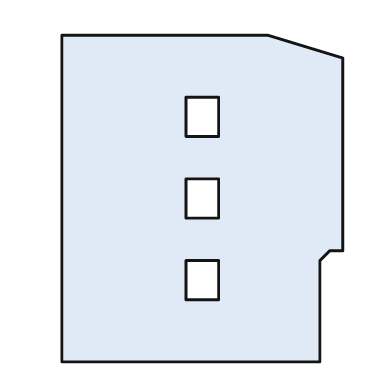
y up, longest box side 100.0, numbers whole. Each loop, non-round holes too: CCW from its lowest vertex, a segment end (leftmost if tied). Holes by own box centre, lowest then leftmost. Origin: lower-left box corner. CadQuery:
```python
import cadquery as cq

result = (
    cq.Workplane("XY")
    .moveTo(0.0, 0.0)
    .lineTo(79.0, 0.0)
    .lineTo(79.0, 31.0)
    .lineTo(82.0, 34.0)
    .lineTo(86.0, 34.0)
    .lineTo(86.0, 93.0)
    .lineTo(63.0, 100.0)
    .lineTo(0.0, 100.0)
    .close()
    .moveTo(38.0, 19.0)
    .lineTo(48.0, 19.0)
    .lineTo(48.0, 31.0)
    .lineTo(38.0, 31.0)
    .close()
    .moveTo(38.0, 44.0)
    .lineTo(48.0, 44.0)
    .lineTo(48.0, 56.0)
    .lineTo(38.0, 56.0)
    .close()
    .moveTo(38.0, 69.0)
    .lineTo(48.0, 69.0)
    .lineTo(48.0, 81.0)
    .lineTo(38.0, 81.0)
    .close()
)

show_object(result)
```